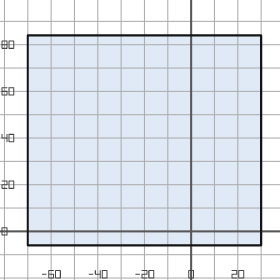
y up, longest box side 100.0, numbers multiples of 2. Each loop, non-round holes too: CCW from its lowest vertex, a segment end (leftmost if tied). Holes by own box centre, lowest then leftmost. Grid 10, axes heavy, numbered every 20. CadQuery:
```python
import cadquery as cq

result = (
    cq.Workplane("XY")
    .moveTo(-70.0, -6.0)
    .lineTo(30.0, -6.0)
    .lineTo(30.0, 84.0)
    .lineTo(-70.0, 84.0)
    .close()
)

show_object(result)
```